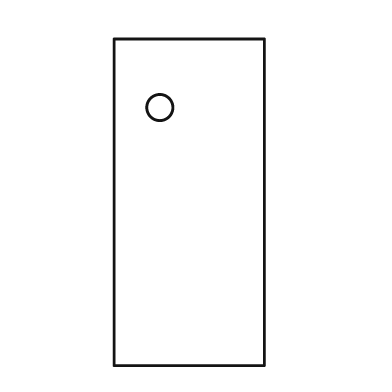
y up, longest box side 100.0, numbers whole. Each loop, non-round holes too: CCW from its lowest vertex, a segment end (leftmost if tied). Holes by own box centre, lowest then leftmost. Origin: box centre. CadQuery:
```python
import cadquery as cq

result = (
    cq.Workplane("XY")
    .moveTo(-23.0, -50.0)
    .lineTo(23.0, -50.0)
    .lineTo(23.0, 50.0)
    .lineTo(-23.0, 50.0)
    .close()
    .moveTo(-9.0, 29.0)
    .circle(4.0)
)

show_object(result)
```